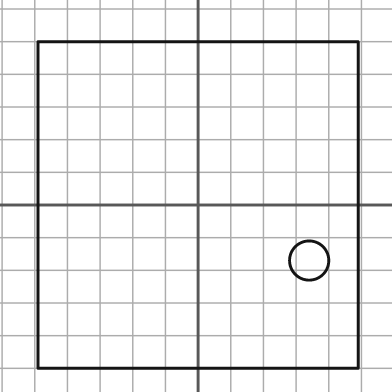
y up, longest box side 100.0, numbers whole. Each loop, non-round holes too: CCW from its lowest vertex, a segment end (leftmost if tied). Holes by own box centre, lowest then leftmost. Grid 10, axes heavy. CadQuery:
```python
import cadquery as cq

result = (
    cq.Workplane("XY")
    .moveTo(-49.0, -50.0)
    .lineTo(49.0, -50.0)
    .lineTo(49.0, 50.0)
    .lineTo(-49.0, 50.0)
    .close()
    .moveTo(34.0, -17.0)
    .circle(6.0)
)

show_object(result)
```